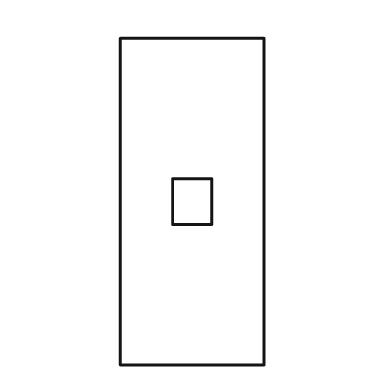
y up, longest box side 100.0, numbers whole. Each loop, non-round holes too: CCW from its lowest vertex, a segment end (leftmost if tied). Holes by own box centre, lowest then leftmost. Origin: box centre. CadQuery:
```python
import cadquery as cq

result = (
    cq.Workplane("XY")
    .moveTo(-22.0, -50.0)
    .lineTo(22.0, -50.0)
    .lineTo(22.0, 50.0)
    .lineTo(-22.0, 50.0)
    .close()
    .moveTo(-6.0, -7.0)
    .lineTo(6.0, -7.0)
    .lineTo(6.0, 7.0)
    .lineTo(-6.0, 7.0)
    .close()
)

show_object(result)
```